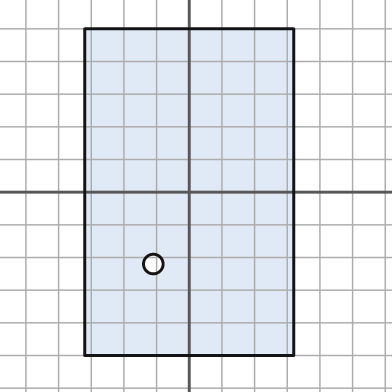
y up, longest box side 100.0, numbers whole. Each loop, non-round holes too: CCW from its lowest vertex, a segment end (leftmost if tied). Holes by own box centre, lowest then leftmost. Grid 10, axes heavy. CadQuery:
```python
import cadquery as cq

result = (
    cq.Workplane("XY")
    .moveTo(-32.0, -50.0)
    .lineTo(32.0, -50.0)
    .lineTo(32.0, 50.0)
    .lineTo(-32.0, 50.0)
    .close()
    .moveTo(-11.0, -22.0)
    .circle(3.0)
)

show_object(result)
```